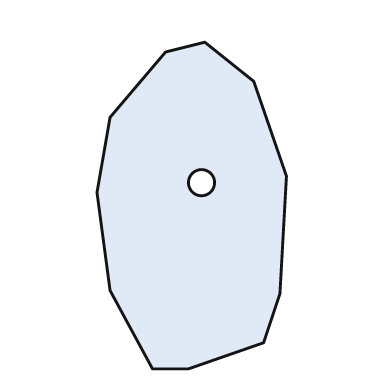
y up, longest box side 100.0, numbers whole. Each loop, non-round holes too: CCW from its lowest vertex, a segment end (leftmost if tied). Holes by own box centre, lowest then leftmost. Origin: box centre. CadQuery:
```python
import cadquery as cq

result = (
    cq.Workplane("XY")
    .moveTo(-12.0, -50.0)
    .lineTo(-1.0, -50.0)
    .lineTo(22.0, -42.0)
    .lineTo(27.0, -27.0)
    .lineTo(29.0, 9.0)
    .lineTo(19.0, 38.0)
    .lineTo(4.0, 50.0)
    .lineTo(-8.0, 47.0)
    .lineTo(-25.0, 27.0)
    .lineTo(-29.0, 4.0)
    .lineTo(-25.0, -26.0)
    .close()
    .moveTo(3.0, 7.0)
    .circle(4.0)
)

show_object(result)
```